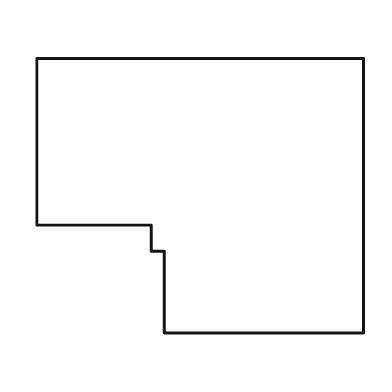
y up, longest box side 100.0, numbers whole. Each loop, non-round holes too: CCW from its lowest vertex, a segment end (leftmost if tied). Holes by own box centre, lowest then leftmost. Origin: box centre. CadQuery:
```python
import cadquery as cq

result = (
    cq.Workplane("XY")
    .moveTo(-11.0, -42.0)
    .lineTo(50.0, -42.0)
    .lineTo(50.0, 42.0)
    .lineTo(-50.0, 42.0)
    .lineTo(-50.0, -9.0)
    .lineTo(-15.0, -9.0)
    .lineTo(-15.0, -17.0)
    .lineTo(-11.0, -17.0)
    .close()
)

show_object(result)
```